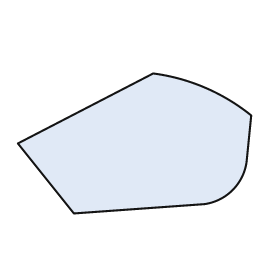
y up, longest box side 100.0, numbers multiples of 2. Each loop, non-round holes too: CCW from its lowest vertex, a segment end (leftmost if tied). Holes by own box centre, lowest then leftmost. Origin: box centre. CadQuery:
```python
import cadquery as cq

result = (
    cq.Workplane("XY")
    .moveTo(-26.0, -30.0)
    .lineTo(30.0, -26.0)
    .threePointArc((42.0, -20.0), (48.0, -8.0))
    .lineTo(50.0, 12.0)
    .threePointArc((30.0, 24.0), (8.0, 30.0))
    .lineTo(-50.0, 0.0)
    .close()
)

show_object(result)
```